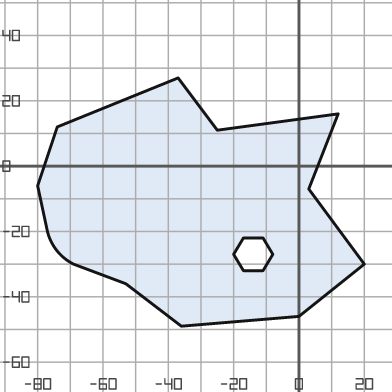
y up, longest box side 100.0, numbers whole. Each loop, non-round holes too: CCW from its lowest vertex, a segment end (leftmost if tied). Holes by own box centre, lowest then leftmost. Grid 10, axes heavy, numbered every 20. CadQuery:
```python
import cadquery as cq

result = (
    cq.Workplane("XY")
    .moveTo(-36.0, -49.0)
    .lineTo(0.0, -46.0)
    .lineTo(20.0, -30.0)
    .lineTo(3.0, -7.0)
    .lineTo(12.0, 16.0)
    .lineTo(-25.0, 11.0)
    .lineTo(-37.0, 27.0)
    .lineTo(-74.0, 12.0)
    .lineTo(-80.0, -6.0)
    .lineTo(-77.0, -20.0)
    .threePointArc((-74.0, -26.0), (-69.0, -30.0))
    .lineTo(-53.0, -36.0)
    .close()
    .moveTo(-17.0, -32.0)
    .lineTo(-11.0, -32.0)
    .lineTo(-8.0, -27.0)
    .lineTo(-11.0, -22.0)
    .lineTo(-17.0, -22.0)
    .lineTo(-20.0, -27.0)
    .close()
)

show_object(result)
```